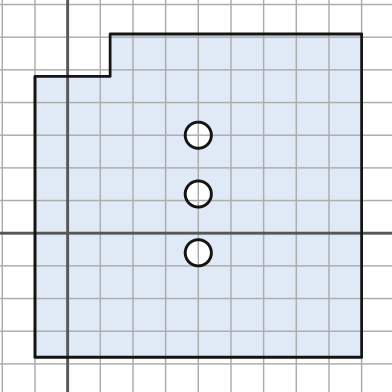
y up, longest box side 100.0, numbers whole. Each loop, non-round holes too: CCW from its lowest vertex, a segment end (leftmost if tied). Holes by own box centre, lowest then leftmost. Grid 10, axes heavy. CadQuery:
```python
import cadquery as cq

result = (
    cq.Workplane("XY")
    .moveTo(-10.0, -38.0)
    .lineTo(90.0, -38.0)
    .lineTo(90.0, 61.0)
    .lineTo(13.0, 61.0)
    .lineTo(13.0, 48.0)
    .lineTo(-10.0, 48.0)
    .close()
    .moveTo(40.0, -6.0)
    .circle(4.0)
    .moveTo(40.0, 12.0)
    .circle(4.0)
    .moveTo(40.0, 30.0)
    .circle(4.0)
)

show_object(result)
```